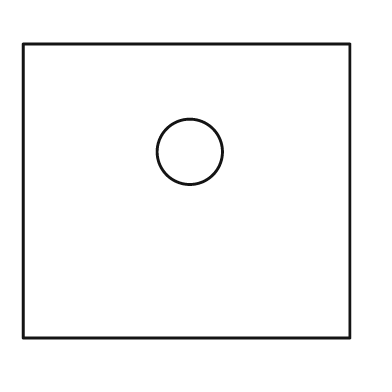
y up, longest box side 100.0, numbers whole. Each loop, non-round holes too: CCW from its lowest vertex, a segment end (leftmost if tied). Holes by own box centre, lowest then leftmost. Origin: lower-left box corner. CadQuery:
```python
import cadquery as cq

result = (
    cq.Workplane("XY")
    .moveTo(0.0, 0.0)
    .lineTo(100.0, 0.0)
    .lineTo(100.0, 90.0)
    .lineTo(0.0, 90.0)
    .close()
    .moveTo(51.0, 57.0)
    .circle(10.0)
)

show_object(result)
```